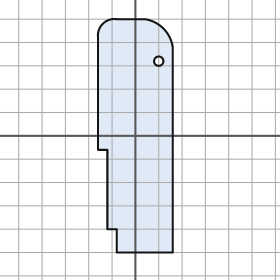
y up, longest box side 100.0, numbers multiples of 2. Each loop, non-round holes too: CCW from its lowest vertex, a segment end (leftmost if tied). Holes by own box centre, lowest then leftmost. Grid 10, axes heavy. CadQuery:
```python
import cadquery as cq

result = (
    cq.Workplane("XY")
    .moveTo(-8.0, -50.0)
    .lineTo(16.0, -50.0)
    .lineTo(16.0, 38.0)
    .threePointArc((12.0, 46.0), (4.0, 50.0))
    .lineTo(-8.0, 50.0)
    .threePointArc((-14.0, 48.0), (-16.0, 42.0))
    .lineTo(-16.0, -6.0)
    .lineTo(-12.0, -6.0)
    .lineTo(-12.0, -40.0)
    .lineTo(-8.0, -40.0)
    .close()
    .moveTo(10.0, 32.0)
    .circle(2.0)
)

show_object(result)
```